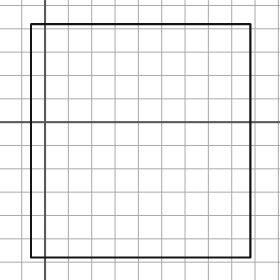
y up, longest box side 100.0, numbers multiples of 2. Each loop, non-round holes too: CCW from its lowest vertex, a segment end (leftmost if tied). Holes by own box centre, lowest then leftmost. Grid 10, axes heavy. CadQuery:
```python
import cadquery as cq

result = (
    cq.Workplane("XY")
    .moveTo(-6.0, -58.0)
    .lineTo(88.0, -58.0)
    .lineTo(88.0, 42.0)
    .lineTo(-6.0, 42.0)
    .close()
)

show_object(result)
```